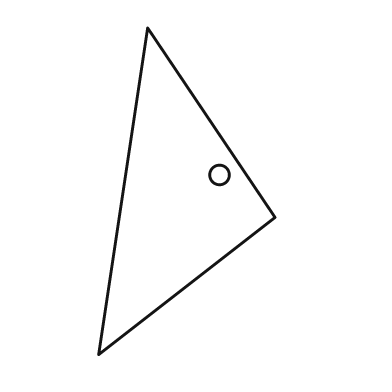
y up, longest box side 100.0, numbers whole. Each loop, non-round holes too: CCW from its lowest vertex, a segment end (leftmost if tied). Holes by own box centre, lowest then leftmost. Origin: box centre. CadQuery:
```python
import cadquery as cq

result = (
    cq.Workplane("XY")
    .moveTo(-27.0, -50.0)
    .lineTo(27.0, -8.0)
    .lineTo(-12.0, 50.0)
    .close()
    .moveTo(10.0, 5.0)
    .circle(3.0)
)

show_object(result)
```